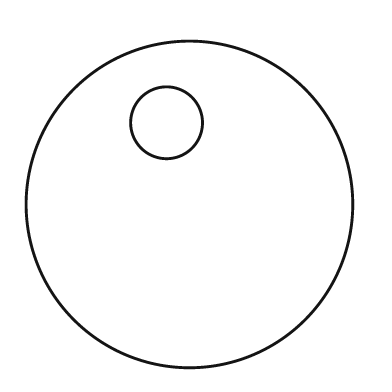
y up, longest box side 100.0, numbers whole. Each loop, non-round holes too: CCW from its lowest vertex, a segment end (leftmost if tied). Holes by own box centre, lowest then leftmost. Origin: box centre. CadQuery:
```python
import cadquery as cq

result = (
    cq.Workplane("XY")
    .moveTo(0.0, 0.0)
    .circle(50.0)
    .moveTo(-7.0, 25.0)
    .circle(11.0)
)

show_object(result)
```